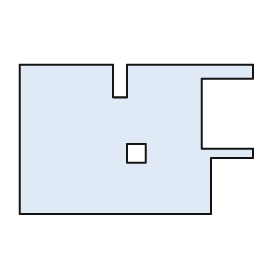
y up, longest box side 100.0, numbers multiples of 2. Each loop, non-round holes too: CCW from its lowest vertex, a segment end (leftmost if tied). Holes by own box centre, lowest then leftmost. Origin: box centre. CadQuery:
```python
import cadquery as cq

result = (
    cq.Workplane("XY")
    .moveTo(-50.0, -32.0)
    .lineTo(32.0, -32.0)
    .lineTo(32.0, -8.0)
    .lineTo(50.0, -8.0)
    .lineTo(50.0, -4.0)
    .lineTo(28.0, -4.0)
    .lineTo(28.0, 26.0)
    .lineTo(50.0, 26.0)
    .lineTo(50.0, 32.0)
    .lineTo(-4.0, 32.0)
    .lineTo(-4.0, 18.0)
    .lineTo(-10.0, 18.0)
    .lineTo(-10.0, 32.0)
    .lineTo(-50.0, 32.0)
    .close()
    .moveTo(-4.0, -10.0)
    .lineTo(4.0, -10.0)
    .lineTo(4.0, -2.0)
    .lineTo(-4.0, -2.0)
    .close()
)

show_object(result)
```